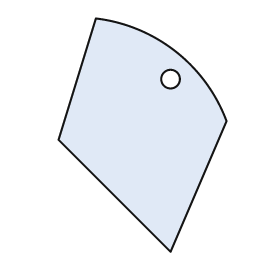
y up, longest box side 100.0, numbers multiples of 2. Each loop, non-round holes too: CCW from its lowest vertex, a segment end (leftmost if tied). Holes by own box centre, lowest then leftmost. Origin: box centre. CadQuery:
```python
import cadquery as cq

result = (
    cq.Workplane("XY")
    .moveTo(12.0, -50.0)
    .lineTo(36.0, 6.0)
    .threePointArc((14.0, 36.0), (-20.0, 50.0))
    .lineTo(-36.0, -2.0)
    .close()
    .moveTo(12.0, 24.0)
    .circle(4.0)
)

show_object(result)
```